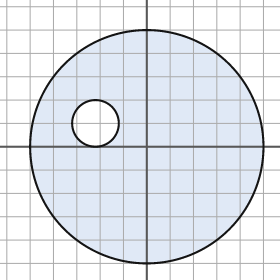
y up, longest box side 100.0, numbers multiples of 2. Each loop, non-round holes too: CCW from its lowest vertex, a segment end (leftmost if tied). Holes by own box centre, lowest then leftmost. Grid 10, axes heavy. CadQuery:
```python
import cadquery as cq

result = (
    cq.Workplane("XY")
    .moveTo(0.0, 0.0)
    .circle(50.0)
    .moveTo(-22.0, 10.0)
    .circle(10.0)
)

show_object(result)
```